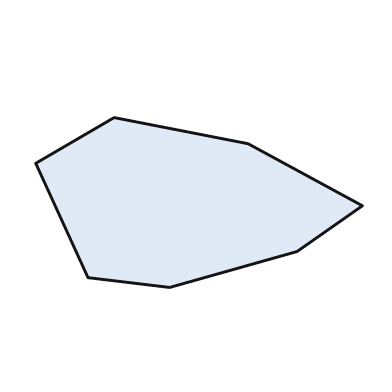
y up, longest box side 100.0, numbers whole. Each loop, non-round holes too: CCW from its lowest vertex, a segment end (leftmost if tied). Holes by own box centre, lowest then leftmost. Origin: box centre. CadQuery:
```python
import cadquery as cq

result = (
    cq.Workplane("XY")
    .moveTo(-9.0, -26.0)
    .lineTo(30.0, -15.0)
    .lineTo(50.0, -1.0)
    .lineTo(15.0, 18.0)
    .lineTo(-26.0, 26.0)
    .lineTo(-50.0, 12.0)
    .lineTo(-34.0, -23.0)
    .close()
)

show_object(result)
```